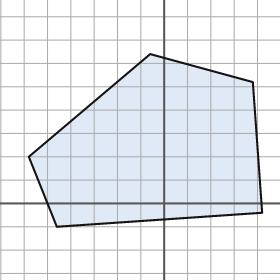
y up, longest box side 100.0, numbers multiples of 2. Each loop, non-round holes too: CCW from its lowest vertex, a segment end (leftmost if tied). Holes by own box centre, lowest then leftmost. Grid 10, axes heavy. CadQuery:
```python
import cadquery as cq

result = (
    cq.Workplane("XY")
    .moveTo(-46.0, -10.0)
    .lineTo(42.0, -4.0)
    .lineTo(38.0, 52.0)
    .lineTo(-6.0, 64.0)
    .lineTo(-58.0, 20.0)
    .close()
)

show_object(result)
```